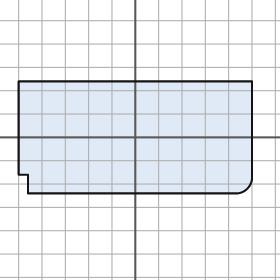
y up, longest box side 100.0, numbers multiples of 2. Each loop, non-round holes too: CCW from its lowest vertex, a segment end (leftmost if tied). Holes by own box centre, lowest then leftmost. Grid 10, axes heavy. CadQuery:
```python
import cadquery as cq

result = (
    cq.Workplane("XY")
    .moveTo(-46.0, -24.0)
    .lineTo(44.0, -24.0)
    .threePointArc((48.0, -22.0), (50.0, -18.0))
    .lineTo(50.0, 24.0)
    .lineTo(-50.0, 24.0)
    .lineTo(-50.0, -16.0)
    .lineTo(-46.0, -16.0)
    .close()
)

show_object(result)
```